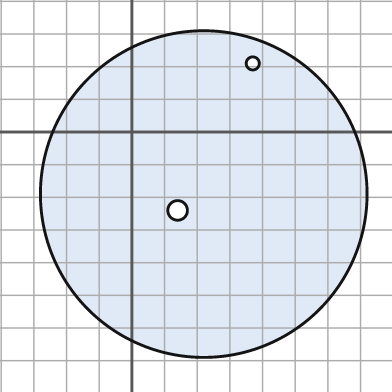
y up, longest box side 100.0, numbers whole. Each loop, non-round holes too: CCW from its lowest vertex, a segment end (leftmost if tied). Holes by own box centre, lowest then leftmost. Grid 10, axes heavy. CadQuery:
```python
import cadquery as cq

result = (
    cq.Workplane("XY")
    .moveTo(22.0, -19.0)
    .circle(50.0)
    .moveTo(14.0, -24.0)
    .circle(3.0)
    .moveTo(37.0, 21.0)
    .circle(2.0)
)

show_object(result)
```